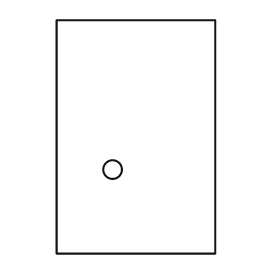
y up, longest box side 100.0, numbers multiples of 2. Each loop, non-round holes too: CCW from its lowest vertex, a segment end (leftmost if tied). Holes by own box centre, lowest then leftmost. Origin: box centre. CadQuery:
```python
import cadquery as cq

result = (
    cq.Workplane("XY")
    .moveTo(-34.0, -50.0)
    .lineTo(34.0, -50.0)
    .lineTo(34.0, 50.0)
    .lineTo(-34.0, 50.0)
    .close()
    .moveTo(-10.0, -14.0)
    .circle(4.0)
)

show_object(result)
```